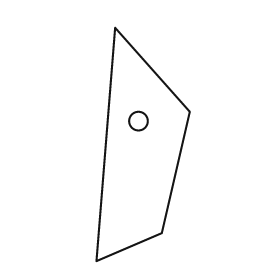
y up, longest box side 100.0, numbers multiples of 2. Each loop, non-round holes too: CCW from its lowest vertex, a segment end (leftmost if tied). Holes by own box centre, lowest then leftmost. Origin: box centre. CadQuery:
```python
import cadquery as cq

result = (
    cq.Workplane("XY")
    .moveTo(-20.0, -50.0)
    .lineTo(8.0, -38.0)
    .lineTo(20.0, 14.0)
    .lineTo(-12.0, 50.0)
    .close()
    .moveTo(-2.0, 10.0)
    .circle(4.0)
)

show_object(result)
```